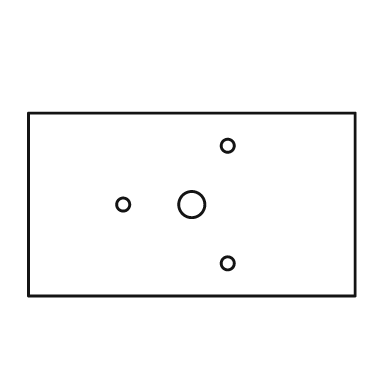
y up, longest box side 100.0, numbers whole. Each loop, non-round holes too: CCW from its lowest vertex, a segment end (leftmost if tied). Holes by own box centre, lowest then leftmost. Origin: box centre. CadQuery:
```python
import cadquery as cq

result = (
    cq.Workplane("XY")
    .moveTo(-50.0, -28.0)
    .lineTo(50.0, -28.0)
    .lineTo(50.0, 28.0)
    .lineTo(-50.0, 28.0)
    .close()
    .moveTo(11.0, -18.0)
    .circle(2.0)
    .moveTo(-21.0, 0.0)
    .circle(2.0)
    .moveTo(0.0, 0.0)
    .circle(4.0)
    .moveTo(11.0, 18.0)
    .circle(2.0)
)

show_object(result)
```